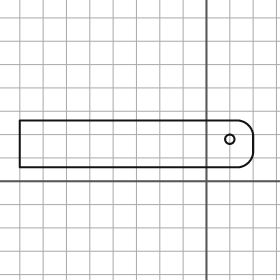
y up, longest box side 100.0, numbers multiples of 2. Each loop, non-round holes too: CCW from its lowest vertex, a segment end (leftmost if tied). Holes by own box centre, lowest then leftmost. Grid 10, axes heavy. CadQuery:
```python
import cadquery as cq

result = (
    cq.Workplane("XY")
    .moveTo(-80.0, 6.0)
    .lineTo(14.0, 6.0)
    .threePointArc((18.0, 8.0), (20.0, 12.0))
    .lineTo(20.0, 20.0)
    .threePointArc((18.0, 24.0), (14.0, 26.0))
    .lineTo(-80.0, 26.0)
    .close()
    .moveTo(10.0, 18.0)
    .circle(2.0)
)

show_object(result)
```